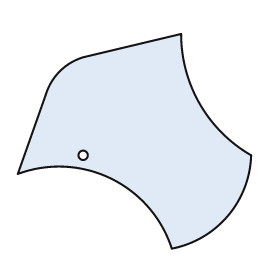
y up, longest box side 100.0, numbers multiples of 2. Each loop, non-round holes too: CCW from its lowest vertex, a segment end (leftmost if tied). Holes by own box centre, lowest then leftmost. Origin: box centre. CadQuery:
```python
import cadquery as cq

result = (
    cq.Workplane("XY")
    .moveTo(16.0, -46.0)
    .threePointArc((40.0, -32.0), (50.0, -6.0))
    .threePointArc((28.0, 16.0), (20.0, 46.0))
    .lineTo(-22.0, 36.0)
    .threePointArc((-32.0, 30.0), (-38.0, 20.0))
    .lineTo(-50.0, -14.0)
    .threePointArc((-10.0, -16.0), (16.0, -46.0))
    .close()
    .moveTo(-22.0, -6.0)
    .circle(2.0)
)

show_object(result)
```